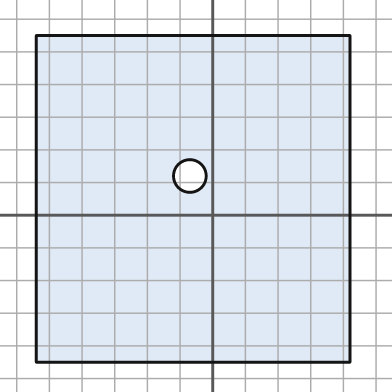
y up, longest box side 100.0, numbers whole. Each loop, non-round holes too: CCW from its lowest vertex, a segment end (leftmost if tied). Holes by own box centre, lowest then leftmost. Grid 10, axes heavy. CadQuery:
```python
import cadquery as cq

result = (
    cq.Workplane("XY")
    .moveTo(-54.0, -45.0)
    .lineTo(42.0, -45.0)
    .lineTo(42.0, 55.0)
    .lineTo(-54.0, 55.0)
    .close()
    .moveTo(-7.0, 12.0)
    .circle(5.0)
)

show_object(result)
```